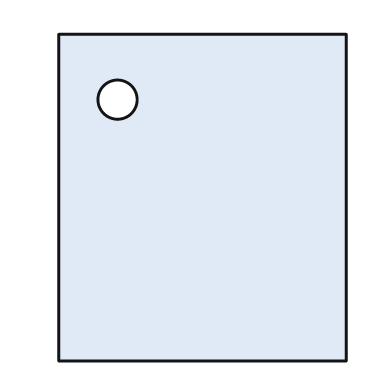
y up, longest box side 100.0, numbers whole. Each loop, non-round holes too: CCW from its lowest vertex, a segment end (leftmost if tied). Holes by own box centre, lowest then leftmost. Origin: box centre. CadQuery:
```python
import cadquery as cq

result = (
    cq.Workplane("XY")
    .moveTo(-44.0, -50.0)
    .lineTo(44.0, -50.0)
    .lineTo(44.0, 50.0)
    .lineTo(-44.0, 50.0)
    .close()
    .moveTo(-26.0, 30.0)
    .circle(6.0)
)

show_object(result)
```